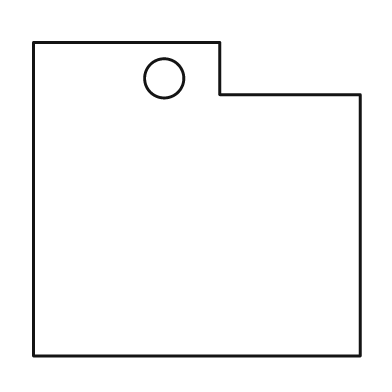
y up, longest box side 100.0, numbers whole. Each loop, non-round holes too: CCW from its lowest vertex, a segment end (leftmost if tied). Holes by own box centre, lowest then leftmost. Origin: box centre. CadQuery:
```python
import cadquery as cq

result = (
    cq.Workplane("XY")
    .moveTo(-50.0, -48.0)
    .lineTo(50.0, -48.0)
    .lineTo(50.0, 32.0)
    .lineTo(7.0, 32.0)
    .lineTo(7.0, 48.0)
    .lineTo(-50.0, 48.0)
    .close()
    .moveTo(-10.0, 37.0)
    .circle(6.0)
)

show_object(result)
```